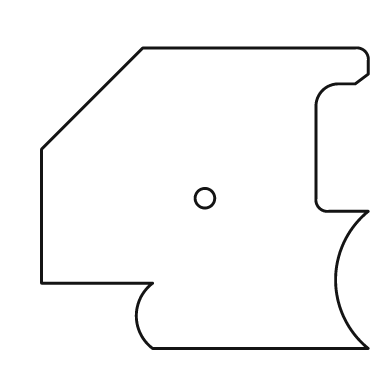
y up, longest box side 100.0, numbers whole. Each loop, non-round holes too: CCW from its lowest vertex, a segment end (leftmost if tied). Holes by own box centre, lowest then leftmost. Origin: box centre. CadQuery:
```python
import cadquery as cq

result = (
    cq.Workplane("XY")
    .moveTo(-16.0, -46.0)
    .lineTo(50.0, -46.0)
    .threePointArc((40.0, -25.0), (50.0, -4.0))
    .lineTo(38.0, -4.0)
    .threePointArc((35.0, -3.0), (34.0, 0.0))
    .lineTo(34.0, 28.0)
    .threePointArc((36.0, 33.0), (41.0, 35.0))
    .lineTo(46.0, 35.0)
    .lineTo(50.0, 38.0)
    .lineTo(50.0, 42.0)
    .threePointArc((49.0, 45.0), (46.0, 46.0))
    .lineTo(-19.0, 46.0)
    .lineTo(-50.0, 15.0)
    .lineTo(-50.0, -26.0)
    .lineTo(-16.0, -26.0)
    .threePointArc((-21.0, -36.0), (-16.0, -46.0))
    .close()
    .moveTo(0.0, 0.0)
    .circle(3.0)
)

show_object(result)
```